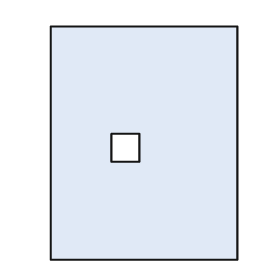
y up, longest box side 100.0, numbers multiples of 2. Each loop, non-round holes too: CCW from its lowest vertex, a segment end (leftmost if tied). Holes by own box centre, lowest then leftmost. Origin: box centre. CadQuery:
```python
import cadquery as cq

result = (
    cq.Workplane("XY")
    .moveTo(-40.0, -50.0)
    .lineTo(40.0, -50.0)
    .lineTo(40.0, 50.0)
    .lineTo(-40.0, 50.0)
    .close()
    .moveTo(-14.0, -8.0)
    .lineTo(-2.0, -8.0)
    .lineTo(-2.0, 4.0)
    .lineTo(-14.0, 4.0)
    .close()
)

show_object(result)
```